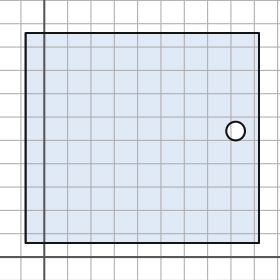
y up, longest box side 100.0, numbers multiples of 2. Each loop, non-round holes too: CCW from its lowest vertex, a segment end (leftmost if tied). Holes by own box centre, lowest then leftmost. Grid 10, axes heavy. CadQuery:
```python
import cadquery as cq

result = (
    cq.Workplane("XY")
    .moveTo(-8.0, 6.0)
    .lineTo(92.0, 6.0)
    .lineTo(92.0, 96.0)
    .lineTo(-8.0, 96.0)
    .close()
    .moveTo(82.0, 54.0)
    .circle(4.0)
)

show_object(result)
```